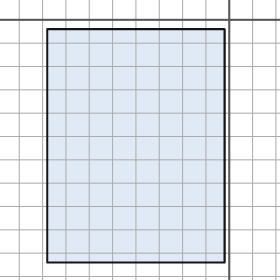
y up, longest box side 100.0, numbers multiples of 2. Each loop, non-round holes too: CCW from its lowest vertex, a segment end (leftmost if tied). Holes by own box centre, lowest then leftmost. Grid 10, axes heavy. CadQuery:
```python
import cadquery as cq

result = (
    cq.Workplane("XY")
    .moveTo(-78.0, -104.0)
    .lineTo(-2.0, -104.0)
    .lineTo(-2.0, -4.0)
    .lineTo(-78.0, -4.0)
    .close()
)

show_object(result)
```